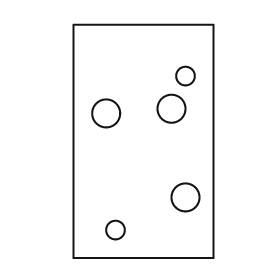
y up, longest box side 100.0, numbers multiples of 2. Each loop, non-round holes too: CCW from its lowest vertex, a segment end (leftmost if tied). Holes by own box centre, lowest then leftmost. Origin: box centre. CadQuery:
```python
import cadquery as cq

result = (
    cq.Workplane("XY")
    .moveTo(-30.0, -50.0)
    .lineTo(30.0, -50.0)
    .lineTo(30.0, 50.0)
    .lineTo(-30.0, 50.0)
    .close()
    .moveTo(-12.0, -38.0)
    .circle(4.0)
    .moveTo(18.0, -24.0)
    .circle(6.0)
    .moveTo(-16.0, 12.0)
    .circle(6.0)
    .moveTo(12.0, 14.0)
    .circle(6.0)
    .moveTo(18.0, 28.0)
    .circle(4.0)
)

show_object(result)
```